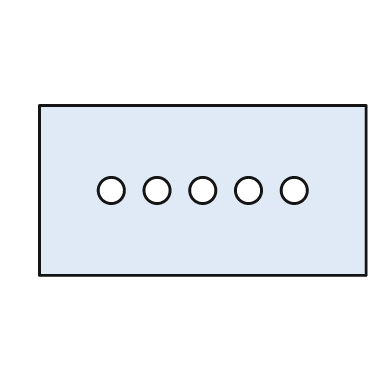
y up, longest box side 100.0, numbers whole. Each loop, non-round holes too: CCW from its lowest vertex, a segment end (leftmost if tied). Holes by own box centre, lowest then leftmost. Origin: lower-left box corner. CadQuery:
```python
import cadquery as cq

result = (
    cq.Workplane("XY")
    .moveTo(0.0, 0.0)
    .lineTo(100.0, 0.0)
    .lineTo(100.0, 52.0)
    .lineTo(0.0, 52.0)
    .close()
    .moveTo(22.0, 26.0)
    .circle(4.0)
    .moveTo(36.0, 26.0)
    .circle(4.0)
    .moveTo(50.0, 26.0)
    .circle(4.0)
    .moveTo(64.0, 26.0)
    .circle(4.0)
    .moveTo(78.0, 26.0)
    .circle(4.0)
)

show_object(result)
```